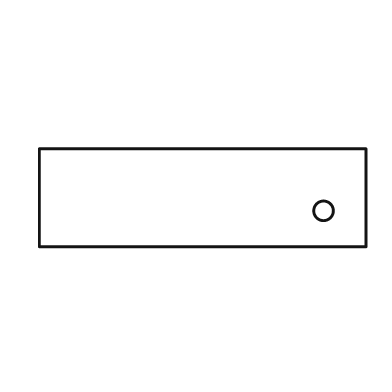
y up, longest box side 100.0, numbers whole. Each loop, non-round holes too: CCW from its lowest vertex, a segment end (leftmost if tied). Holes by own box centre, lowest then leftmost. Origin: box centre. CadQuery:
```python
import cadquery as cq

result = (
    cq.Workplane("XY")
    .moveTo(-50.0, -15.0)
    .lineTo(50.0, -15.0)
    .lineTo(50.0, 15.0)
    .lineTo(-50.0, 15.0)
    .close()
    .moveTo(37.0, -4.0)
    .circle(3.0)
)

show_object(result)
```